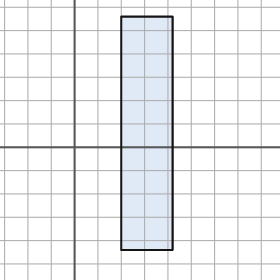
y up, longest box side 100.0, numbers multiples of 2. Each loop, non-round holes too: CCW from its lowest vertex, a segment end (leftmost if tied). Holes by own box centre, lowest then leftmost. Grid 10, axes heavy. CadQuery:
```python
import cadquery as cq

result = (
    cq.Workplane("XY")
    .moveTo(20.0, -44.0)
    .lineTo(42.0, -44.0)
    .lineTo(42.0, 56.0)
    .lineTo(20.0, 56.0)
    .close()
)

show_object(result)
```